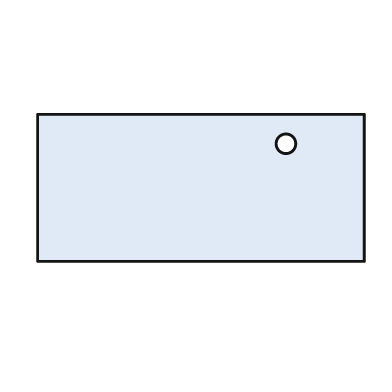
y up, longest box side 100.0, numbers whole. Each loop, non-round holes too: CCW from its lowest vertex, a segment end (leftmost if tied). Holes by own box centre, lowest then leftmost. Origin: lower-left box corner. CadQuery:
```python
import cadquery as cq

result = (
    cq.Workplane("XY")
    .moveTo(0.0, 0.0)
    .lineTo(100.0, 0.0)
    .lineTo(100.0, 45.0)
    .lineTo(0.0, 45.0)
    .close()
    .moveTo(76.0, 36.0)
    .circle(3.0)
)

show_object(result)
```